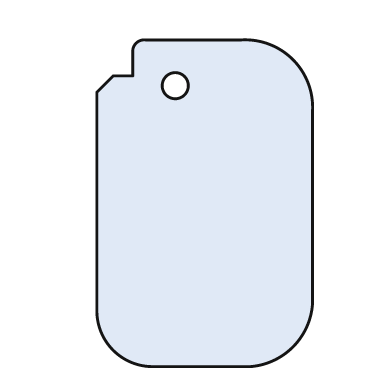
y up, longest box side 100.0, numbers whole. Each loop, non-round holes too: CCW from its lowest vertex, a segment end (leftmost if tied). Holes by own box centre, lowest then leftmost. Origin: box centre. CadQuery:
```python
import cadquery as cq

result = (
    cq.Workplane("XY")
    .moveTo(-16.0, -50.0)
    .lineTo(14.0, -50.0)
    .threePointArc((27.0, -44.0), (33.0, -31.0))
    .lineTo(33.0, 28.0)
    .threePointArc((27.0, 44.0), (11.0, 50.0))
    .lineTo(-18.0, 50.0)
    .threePointArc((-21.0, 49.0), (-22.0, 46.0))
    .lineTo(-22.0, 39.0)
    .lineTo(-28.0, 39.0)
    .lineTo(-33.0, 34.0)
    .lineTo(-33.0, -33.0)
    .threePointArc((-28.0, -45.0), (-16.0, -50.0))
    .close()
    .moveTo(-9.0, 36.0)
    .circle(4.0)
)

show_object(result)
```